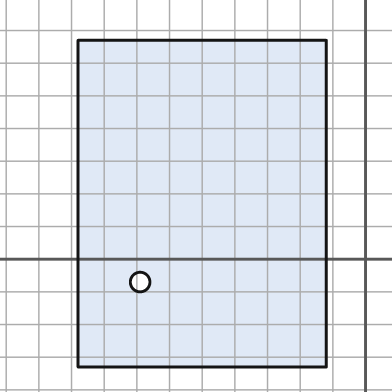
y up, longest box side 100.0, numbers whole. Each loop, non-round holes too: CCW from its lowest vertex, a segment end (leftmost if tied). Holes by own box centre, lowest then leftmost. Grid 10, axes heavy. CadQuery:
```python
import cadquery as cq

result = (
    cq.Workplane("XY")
    .moveTo(-88.0, -33.0)
    .lineTo(-12.0, -33.0)
    .lineTo(-12.0, 67.0)
    .lineTo(-88.0, 67.0)
    .close()
    .moveTo(-69.0, -7.0)
    .circle(3.0)
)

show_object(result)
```